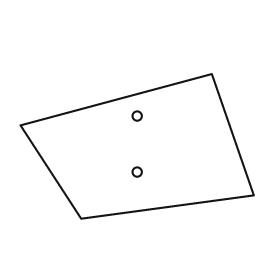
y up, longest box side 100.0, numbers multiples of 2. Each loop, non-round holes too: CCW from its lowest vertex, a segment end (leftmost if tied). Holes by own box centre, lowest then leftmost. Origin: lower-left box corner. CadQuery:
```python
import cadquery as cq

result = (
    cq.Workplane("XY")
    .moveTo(26.0, 0.0)
    .lineTo(100.0, 10.0)
    .lineTo(82.0, 62.0)
    .lineTo(0.0, 40.0)
    .close()
    .moveTo(50.0, 20.0)
    .circle(2.0)
    .moveTo(50.0, 44.0)
    .circle(2.0)
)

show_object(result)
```